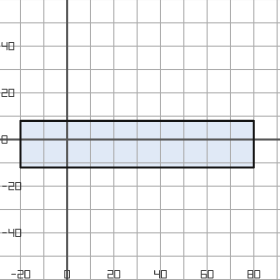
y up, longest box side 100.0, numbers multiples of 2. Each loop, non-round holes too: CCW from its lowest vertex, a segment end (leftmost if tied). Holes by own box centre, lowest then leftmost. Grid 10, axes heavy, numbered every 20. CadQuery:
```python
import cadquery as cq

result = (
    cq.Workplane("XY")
    .moveTo(-20.0, -12.0)
    .lineTo(80.0, -12.0)
    .lineTo(80.0, 8.0)
    .lineTo(-20.0, 8.0)
    .close()
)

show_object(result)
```